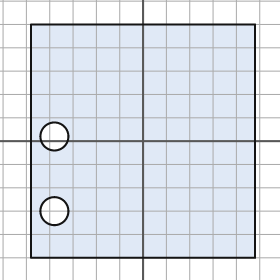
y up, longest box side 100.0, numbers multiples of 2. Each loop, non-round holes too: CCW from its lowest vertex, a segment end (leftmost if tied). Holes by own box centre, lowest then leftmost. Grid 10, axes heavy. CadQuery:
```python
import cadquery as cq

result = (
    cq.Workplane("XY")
    .moveTo(-48.0, -50.0)
    .lineTo(48.0, -50.0)
    .lineTo(48.0, 50.0)
    .lineTo(-48.0, 50.0)
    .close()
    .moveTo(-38.0, -30.0)
    .circle(6.0)
    .moveTo(-38.0, 2.0)
    .circle(6.0)
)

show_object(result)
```